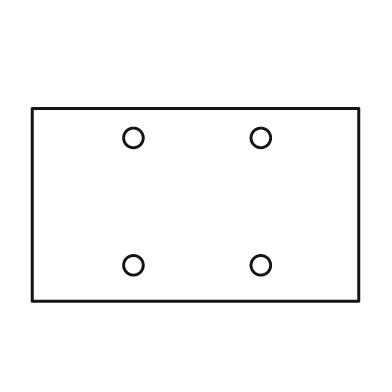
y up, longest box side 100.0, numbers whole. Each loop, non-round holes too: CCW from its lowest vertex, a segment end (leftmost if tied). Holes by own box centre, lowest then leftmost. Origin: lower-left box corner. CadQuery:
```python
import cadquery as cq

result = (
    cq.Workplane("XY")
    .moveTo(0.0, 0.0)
    .lineTo(100.0, 0.0)
    .lineTo(100.0, 59.0)
    .lineTo(0.0, 59.0)
    .close()
    .moveTo(31.0, 11.0)
    .circle(3.0)
    .moveTo(70.0, 11.0)
    .circle(3.0)
    .moveTo(31.0, 50.0)
    .circle(3.0)
    .moveTo(70.0, 50.0)
    .circle(3.0)
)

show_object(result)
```